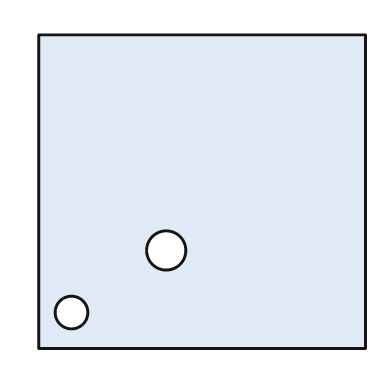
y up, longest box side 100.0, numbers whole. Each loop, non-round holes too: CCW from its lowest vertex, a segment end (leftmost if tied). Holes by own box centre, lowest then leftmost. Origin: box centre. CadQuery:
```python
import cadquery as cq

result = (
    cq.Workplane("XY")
    .moveTo(-50.0, -48.0)
    .lineTo(50.0, -48.0)
    .lineTo(50.0, 48.0)
    .lineTo(-50.0, 48.0)
    .close()
    .moveTo(-40.0, -37.0)
    .circle(5.0)
    .moveTo(-11.0, -18.0)
    .circle(6.0)
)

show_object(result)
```